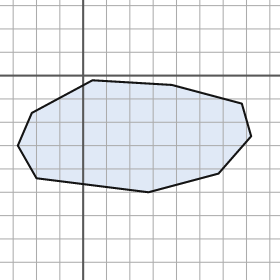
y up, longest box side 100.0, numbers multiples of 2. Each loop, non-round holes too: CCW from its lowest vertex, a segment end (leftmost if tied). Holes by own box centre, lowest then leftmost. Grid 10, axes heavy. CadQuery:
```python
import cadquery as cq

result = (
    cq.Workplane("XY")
    .moveTo(28.0, -50.0)
    .lineTo(58.0, -42.0)
    .lineTo(72.0, -26.0)
    .lineTo(68.0, -12.0)
    .lineTo(38.0, -4.0)
    .lineTo(4.0, -2.0)
    .lineTo(-22.0, -16.0)
    .lineTo(-28.0, -30.0)
    .lineTo(-20.0, -44.0)
    .close()
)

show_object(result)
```